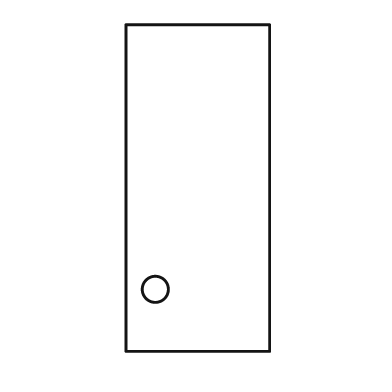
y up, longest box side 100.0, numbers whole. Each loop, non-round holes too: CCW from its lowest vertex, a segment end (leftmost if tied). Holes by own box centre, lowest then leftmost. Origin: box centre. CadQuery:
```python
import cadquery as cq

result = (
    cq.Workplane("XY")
    .moveTo(-22.0, -50.0)
    .lineTo(22.0, -50.0)
    .lineTo(22.0, 50.0)
    .lineTo(-22.0, 50.0)
    .close()
    .moveTo(-13.0, -31.0)
    .circle(4.0)
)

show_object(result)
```